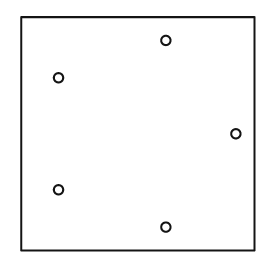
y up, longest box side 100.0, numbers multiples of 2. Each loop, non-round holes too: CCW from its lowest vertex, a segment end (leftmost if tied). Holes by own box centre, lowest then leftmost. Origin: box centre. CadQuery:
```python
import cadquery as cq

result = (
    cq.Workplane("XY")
    .moveTo(-50.0, -50.0)
    .lineTo(50.0, -50.0)
    .lineTo(50.0, 50.0)
    .lineTo(-50.0, 50.0)
    .close()
    .moveTo(12.0, -40.0)
    .circle(2.0)
    .moveTo(-34.0, -24.0)
    .circle(2.0)
    .moveTo(42.0, 0.0)
    .circle(2.0)
    .moveTo(-34.0, 24.0)
    .circle(2.0)
    .moveTo(12.0, 40.0)
    .circle(2.0)
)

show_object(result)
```